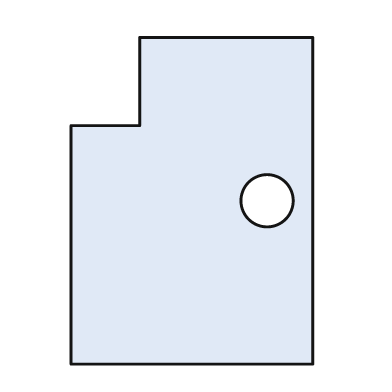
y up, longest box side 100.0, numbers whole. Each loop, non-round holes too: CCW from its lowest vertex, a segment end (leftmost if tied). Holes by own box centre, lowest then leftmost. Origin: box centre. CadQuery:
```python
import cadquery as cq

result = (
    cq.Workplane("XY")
    .moveTo(-37.0, -50.0)
    .lineTo(37.0, -50.0)
    .lineTo(37.0, 50.0)
    .lineTo(-16.0, 50.0)
    .lineTo(-16.0, 23.0)
    .lineTo(-37.0, 23.0)
    .close()
    .moveTo(23.0, 0.0)
    .circle(8.0)
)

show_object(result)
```